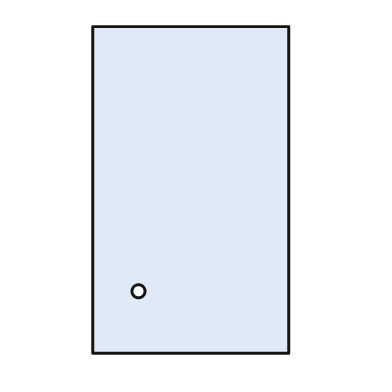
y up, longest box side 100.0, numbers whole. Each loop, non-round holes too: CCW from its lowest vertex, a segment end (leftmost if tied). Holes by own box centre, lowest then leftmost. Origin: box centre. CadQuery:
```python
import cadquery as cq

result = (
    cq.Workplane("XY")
    .moveTo(-30.0, -50.0)
    .lineTo(30.0, -50.0)
    .lineTo(30.0, 50.0)
    .lineTo(-30.0, 50.0)
    .close()
    .moveTo(-16.0, -31.0)
    .circle(2.0)
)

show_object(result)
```